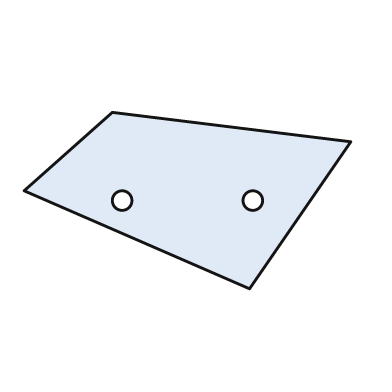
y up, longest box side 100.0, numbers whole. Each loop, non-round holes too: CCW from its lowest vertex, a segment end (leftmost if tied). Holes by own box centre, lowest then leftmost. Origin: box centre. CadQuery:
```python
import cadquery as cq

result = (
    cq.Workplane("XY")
    .moveTo(19.0, -27.0)
    .lineTo(50.0, 18.0)
    .lineTo(-23.0, 27.0)
    .lineTo(-50.0, 3.0)
    .close()
    .moveTo(-20.0, 0.0)
    .circle(3.0)
    .moveTo(20.0, 0.0)
    .circle(3.0)
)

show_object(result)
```